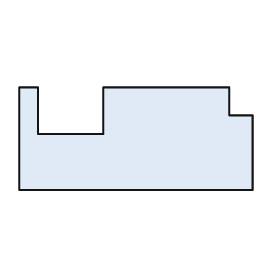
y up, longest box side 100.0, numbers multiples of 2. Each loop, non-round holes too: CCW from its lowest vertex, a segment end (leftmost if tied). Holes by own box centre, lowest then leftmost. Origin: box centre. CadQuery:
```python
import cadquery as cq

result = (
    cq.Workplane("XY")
    .moveTo(-50.0, -22.0)
    .lineTo(50.0, -22.0)
    .lineTo(50.0, 10.0)
    .lineTo(40.0, 10.0)
    .lineTo(40.0, 22.0)
    .lineTo(-14.0, 22.0)
    .lineTo(-14.0, 2.0)
    .lineTo(-42.0, 2.0)
    .lineTo(-42.0, 22.0)
    .lineTo(-50.0, 22.0)
    .close()
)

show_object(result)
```